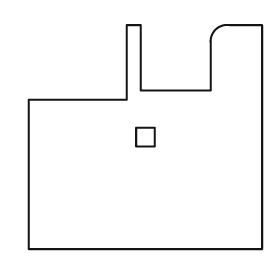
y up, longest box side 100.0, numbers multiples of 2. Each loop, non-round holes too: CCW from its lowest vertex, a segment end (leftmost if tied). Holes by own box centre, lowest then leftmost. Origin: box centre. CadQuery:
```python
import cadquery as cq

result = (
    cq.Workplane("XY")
    .moveTo(-50.0, -48.0)
    .lineTo(50.0, -48.0)
    .lineTo(50.0, 48.0)
    .lineTo(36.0, 48.0)
    .threePointArc((30.0, 46.0), (28.0, 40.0))
    .lineTo(28.0, 20.0)
    .lineTo(-2.0, 20.0)
    .lineTo(-2.0, 48.0)
    .lineTo(-8.0, 48.0)
    .lineTo(-8.0, 16.0)
    .lineTo(-50.0, 16.0)
    .close()
    .moveTo(-4.0, -4.0)
    .lineTo(4.0, -4.0)
    .lineTo(4.0, 4.0)
    .lineTo(-4.0, 4.0)
    .close()
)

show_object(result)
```